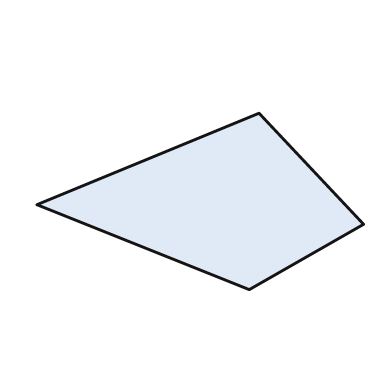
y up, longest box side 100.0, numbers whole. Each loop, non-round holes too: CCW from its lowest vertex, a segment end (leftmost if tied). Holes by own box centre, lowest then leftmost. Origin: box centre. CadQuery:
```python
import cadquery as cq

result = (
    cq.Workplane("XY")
    .moveTo(15.0, -27.0)
    .lineTo(50.0, -7.0)
    .lineTo(18.0, 27.0)
    .lineTo(-50.0, -1.0)
    .close()
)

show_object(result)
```